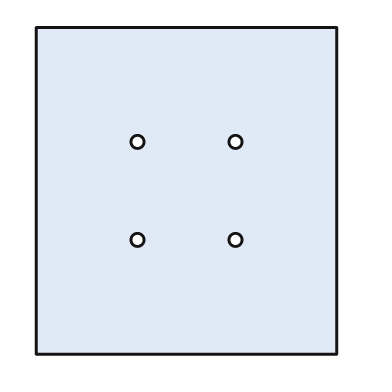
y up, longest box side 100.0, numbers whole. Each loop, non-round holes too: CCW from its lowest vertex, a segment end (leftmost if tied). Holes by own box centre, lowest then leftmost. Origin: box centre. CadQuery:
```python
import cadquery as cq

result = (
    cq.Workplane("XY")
    .moveTo(-46.0, -50.0)
    .lineTo(46.0, -50.0)
    .lineTo(46.0, 50.0)
    .lineTo(-46.0, 50.0)
    .close()
    .moveTo(-15.0, -15.0)
    .circle(2.0)
    .moveTo(15.0, -15.0)
    .circle(2.0)
    .moveTo(-15.0, 15.0)
    .circle(2.0)
    .moveTo(15.0, 15.0)
    .circle(2.0)
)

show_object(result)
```